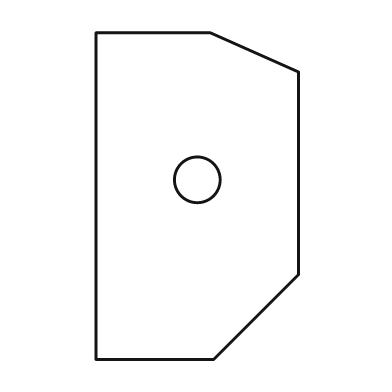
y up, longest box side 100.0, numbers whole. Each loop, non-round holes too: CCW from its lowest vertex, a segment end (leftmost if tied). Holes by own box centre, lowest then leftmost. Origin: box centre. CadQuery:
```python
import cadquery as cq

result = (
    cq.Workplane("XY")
    .moveTo(-31.0, -50.0)
    .lineTo(5.0, -50.0)
    .lineTo(31.0, -24.0)
    .lineTo(31.0, 38.0)
    .lineTo(4.0, 50.0)
    .lineTo(-31.0, 50.0)
    .close()
    .moveTo(0.0, 5.0)
    .circle(7.0)
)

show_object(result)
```